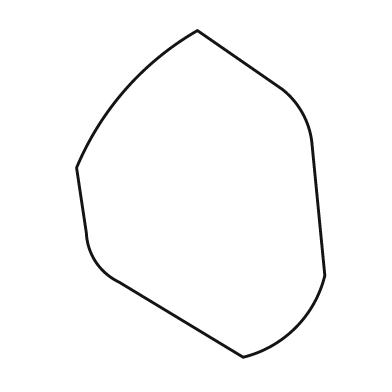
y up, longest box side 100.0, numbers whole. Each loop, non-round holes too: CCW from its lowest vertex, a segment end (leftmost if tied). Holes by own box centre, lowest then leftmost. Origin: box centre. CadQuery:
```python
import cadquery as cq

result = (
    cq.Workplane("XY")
    .moveTo(13.0, -50.0)
    .threePointArc((29.0, -41.0), (38.0, -25.0))
    .lineTo(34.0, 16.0)
    .threePointArc((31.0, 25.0), (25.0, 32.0))
    .lineTo(-1.0, 50.0)
    .threePointArc((-23.0, 32.0), (-38.0, 8.0))
    .lineTo(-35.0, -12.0)
    .threePointArc((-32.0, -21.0), (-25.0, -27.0))
    .close()
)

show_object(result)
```